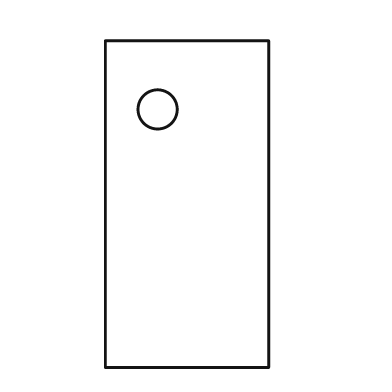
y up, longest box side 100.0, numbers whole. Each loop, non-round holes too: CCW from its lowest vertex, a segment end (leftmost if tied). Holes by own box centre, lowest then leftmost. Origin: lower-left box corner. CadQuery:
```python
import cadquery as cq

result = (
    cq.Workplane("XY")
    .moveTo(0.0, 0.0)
    .lineTo(50.0, 0.0)
    .lineTo(50.0, 100.0)
    .lineTo(0.0, 100.0)
    .close()
    .moveTo(16.0, 79.0)
    .circle(6.0)
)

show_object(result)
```